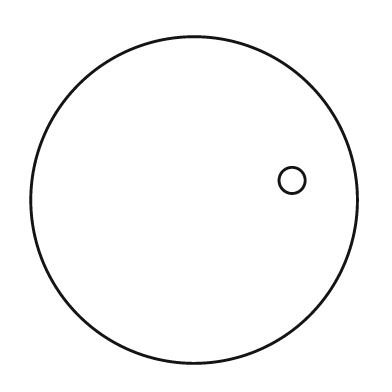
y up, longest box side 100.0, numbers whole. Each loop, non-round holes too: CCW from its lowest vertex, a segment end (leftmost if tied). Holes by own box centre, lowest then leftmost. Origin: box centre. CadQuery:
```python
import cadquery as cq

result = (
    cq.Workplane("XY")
    .moveTo(0.0, 0.0)
    .circle(50.0)
    .moveTo(30.0, 6.0)
    .circle(4.0)
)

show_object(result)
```